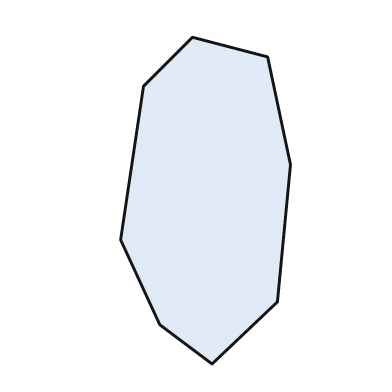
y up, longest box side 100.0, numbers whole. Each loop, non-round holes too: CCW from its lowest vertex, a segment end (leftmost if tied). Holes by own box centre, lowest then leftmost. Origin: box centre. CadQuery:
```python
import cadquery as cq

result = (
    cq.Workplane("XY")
    .moveTo(2.0, -50.0)
    .lineTo(22.0, -31.0)
    .lineTo(26.0, 11.0)
    .lineTo(19.0, 44.0)
    .lineTo(-4.0, 50.0)
    .lineTo(-19.0, 35.0)
    .lineTo(-26.0, -12.0)
    .lineTo(-14.0, -38.0)
    .close()
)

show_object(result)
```